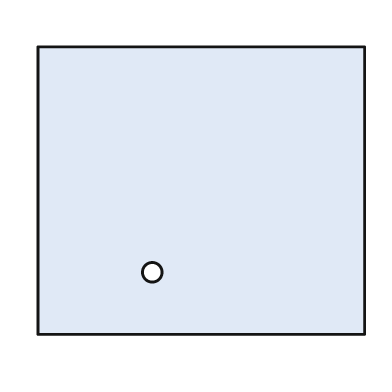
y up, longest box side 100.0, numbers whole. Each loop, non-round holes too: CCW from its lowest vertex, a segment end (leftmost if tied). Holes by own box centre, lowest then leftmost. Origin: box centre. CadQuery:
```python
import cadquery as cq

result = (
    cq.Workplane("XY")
    .moveTo(-50.0, -44.0)
    .lineTo(50.0, -44.0)
    .lineTo(50.0, 44.0)
    .lineTo(-50.0, 44.0)
    .close()
    .moveTo(-15.0, -25.0)
    .circle(3.0)
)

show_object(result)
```